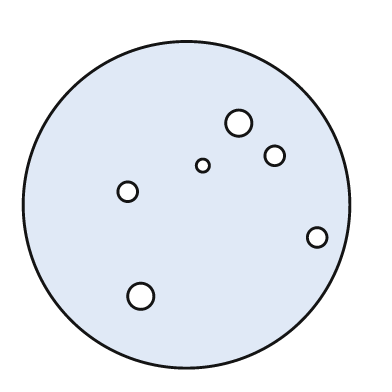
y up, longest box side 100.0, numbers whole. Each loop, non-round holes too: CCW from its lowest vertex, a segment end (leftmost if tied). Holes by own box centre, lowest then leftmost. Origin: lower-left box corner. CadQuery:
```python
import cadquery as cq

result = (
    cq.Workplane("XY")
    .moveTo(50.0, 50.0)
    .circle(50.0)
    .moveTo(36.0, 22.0)
    .circle(4.0)
    .moveTo(90.0, 40.0)
    .circle(3.0)
    .moveTo(32.0, 54.0)
    .circle(3.0)
    .moveTo(55.0, 62.0)
    .circle(2.0)
    .moveTo(77.0, 65.0)
    .circle(3.0)
    .moveTo(66.0, 75.0)
    .circle(4.0)
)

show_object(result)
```